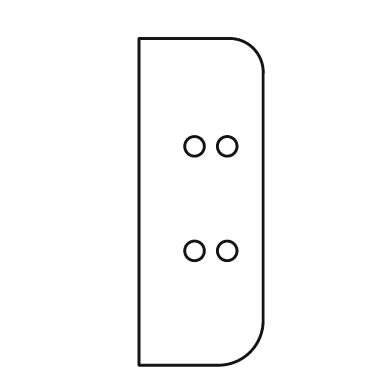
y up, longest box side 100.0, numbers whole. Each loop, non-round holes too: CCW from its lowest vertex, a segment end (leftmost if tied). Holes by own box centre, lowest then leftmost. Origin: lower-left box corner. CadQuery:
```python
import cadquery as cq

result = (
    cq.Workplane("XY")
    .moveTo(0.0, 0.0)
    .lineTo(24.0, 0.0)
    .threePointArc((34.0, 4.0), (38.0, 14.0))
    .lineTo(38.0, 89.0)
    .threePointArc((35.0, 97.0), (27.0, 100.0))
    .lineTo(0.0, 100.0)
    .close()
    .moveTo(17.0, 35.0)
    .circle(3.0)
    .moveTo(27.0, 35.0)
    .circle(3.0)
    .moveTo(17.0, 67.0)
    .circle(3.0)
    .moveTo(27.0, 67.0)
    .circle(3.0)
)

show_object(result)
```